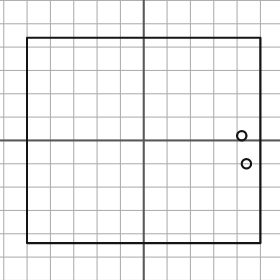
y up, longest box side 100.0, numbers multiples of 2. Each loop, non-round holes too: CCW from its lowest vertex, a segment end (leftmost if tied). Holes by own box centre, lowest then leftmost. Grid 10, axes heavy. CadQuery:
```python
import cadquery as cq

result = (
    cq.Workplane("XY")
    .moveTo(-50.0, -44.0)
    .lineTo(50.0, -44.0)
    .lineTo(50.0, 44.0)
    .lineTo(-50.0, 44.0)
    .close()
    .moveTo(44.0, -10.0)
    .circle(2.0)
    .moveTo(42.0, 2.0)
    .circle(2.0)
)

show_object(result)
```